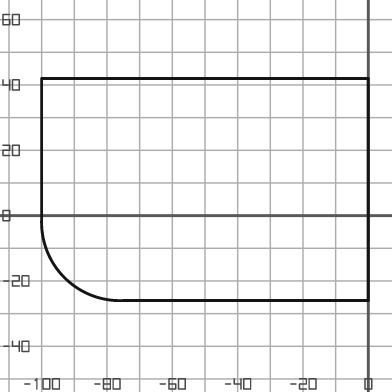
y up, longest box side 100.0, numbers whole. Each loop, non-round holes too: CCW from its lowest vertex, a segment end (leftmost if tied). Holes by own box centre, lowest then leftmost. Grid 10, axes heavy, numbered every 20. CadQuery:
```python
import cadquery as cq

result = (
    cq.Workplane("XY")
    .moveTo(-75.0, -26.0)
    .lineTo(0.0, -26.0)
    .lineTo(0.0, 42.0)
    .lineTo(-100.0, 42.0)
    .lineTo(-100.0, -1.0)
    .threePointArc((-93.0, -19.0), (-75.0, -26.0))
    .close()
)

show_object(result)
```